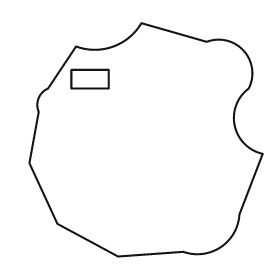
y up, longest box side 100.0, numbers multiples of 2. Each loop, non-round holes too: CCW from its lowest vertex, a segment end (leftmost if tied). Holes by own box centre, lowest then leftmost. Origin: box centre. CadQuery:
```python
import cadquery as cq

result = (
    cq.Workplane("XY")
    .moveTo(-12.0, -50.0)
    .lineTo(16.0, -48.0)
    .threePointArc((32.0, -46.0), (40.0, -32.0))
    .lineTo(50.0, -6.0)
    .threePointArc((38.0, 6.0), (44.0, 22.0))
    .threePointArc((42.0, 38.0), (26.0, 42.0))
    .lineTo(-2.0, 50.0)
    .threePointArc((-14.0, 40.0), (-30.0, 40.0))
    .lineTo(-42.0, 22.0)
    .threePointArc((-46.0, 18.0), (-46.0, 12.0))
    .lineTo(-50.0, -10.0)
    .lineTo(-38.0, -36.0)
    .close()
    .moveTo(-32.0, 22.0)
    .lineTo(-16.0, 22.0)
    .lineTo(-16.0, 30.0)
    .lineTo(-32.0, 30.0)
    .close()
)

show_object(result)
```